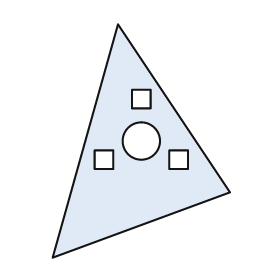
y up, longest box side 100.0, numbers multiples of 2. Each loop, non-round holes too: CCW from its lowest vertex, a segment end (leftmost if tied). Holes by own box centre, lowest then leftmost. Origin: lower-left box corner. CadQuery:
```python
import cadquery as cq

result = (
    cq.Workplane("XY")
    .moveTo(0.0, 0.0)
    .lineTo(76.0, 28.0)
    .lineTo(28.0, 100.0)
    .close()
    .moveTo(18.0, 38.0)
    .lineTo(26.0, 38.0)
    .lineTo(26.0, 46.0)
    .lineTo(18.0, 46.0)
    .close()
    .moveTo(50.0, 38.0)
    .lineTo(58.0, 38.0)
    .lineTo(58.0, 46.0)
    .lineTo(50.0, 46.0)
    .close()
    .moveTo(38.0, 50.0)
    .circle(8.0)
    .moveTo(34.0, 64.0)
    .lineTo(42.0, 64.0)
    .lineTo(42.0, 72.0)
    .lineTo(34.0, 72.0)
    .close()
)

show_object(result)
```